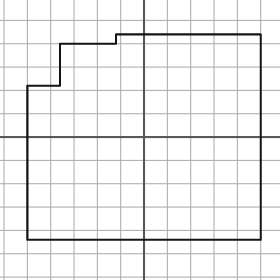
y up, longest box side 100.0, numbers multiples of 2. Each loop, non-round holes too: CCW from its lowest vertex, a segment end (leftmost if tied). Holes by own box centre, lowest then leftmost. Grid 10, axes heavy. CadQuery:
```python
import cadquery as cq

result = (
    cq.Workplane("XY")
    .moveTo(-50.0, -44.0)
    .lineTo(50.0, -44.0)
    .lineTo(50.0, 44.0)
    .lineTo(-12.0, 44.0)
    .lineTo(-12.0, 40.0)
    .lineTo(-36.0, 40.0)
    .lineTo(-36.0, 22.0)
    .lineTo(-50.0, 22.0)
    .close()
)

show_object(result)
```